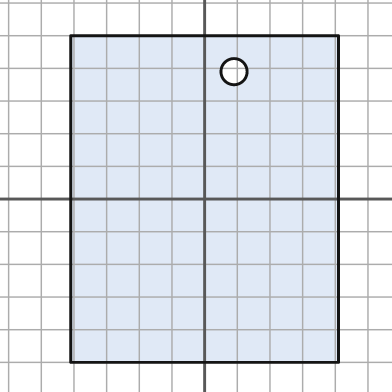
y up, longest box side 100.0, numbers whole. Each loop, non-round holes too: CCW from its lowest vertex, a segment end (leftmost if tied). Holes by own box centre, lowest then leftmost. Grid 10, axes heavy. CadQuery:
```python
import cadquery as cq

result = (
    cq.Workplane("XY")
    .moveTo(-41.0, -50.0)
    .lineTo(41.0, -50.0)
    .lineTo(41.0, 50.0)
    .lineTo(-41.0, 50.0)
    .close()
    .moveTo(9.0, 39.0)
    .circle(4.0)
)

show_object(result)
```